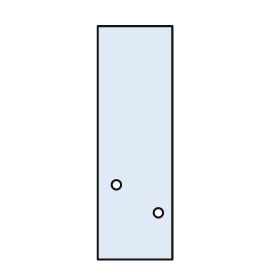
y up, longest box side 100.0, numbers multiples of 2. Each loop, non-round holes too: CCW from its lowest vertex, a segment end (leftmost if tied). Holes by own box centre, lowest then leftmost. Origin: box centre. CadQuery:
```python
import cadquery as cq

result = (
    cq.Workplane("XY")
    .moveTo(-16.0, -50.0)
    .lineTo(16.0, -50.0)
    .lineTo(16.0, 50.0)
    .lineTo(-16.0, 50.0)
    .close()
    .moveTo(10.0, -30.0)
    .circle(2.0)
    .moveTo(-8.0, -18.0)
    .circle(2.0)
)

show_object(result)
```